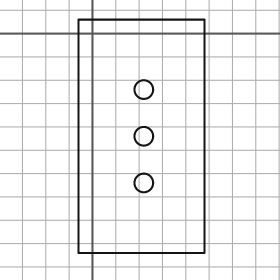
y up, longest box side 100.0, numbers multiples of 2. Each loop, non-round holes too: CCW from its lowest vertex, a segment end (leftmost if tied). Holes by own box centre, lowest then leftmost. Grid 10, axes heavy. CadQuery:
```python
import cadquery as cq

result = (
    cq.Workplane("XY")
    .moveTo(-6.0, -94.0)
    .lineTo(48.0, -94.0)
    .lineTo(48.0, 6.0)
    .lineTo(-6.0, 6.0)
    .close()
    .moveTo(22.0, -64.0)
    .circle(4.0)
    .moveTo(22.0, -44.0)
    .circle(4.0)
    .moveTo(22.0, -24.0)
    .circle(4.0)
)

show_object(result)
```